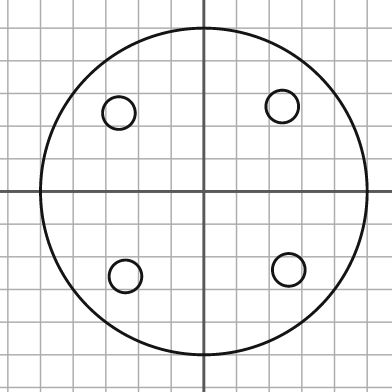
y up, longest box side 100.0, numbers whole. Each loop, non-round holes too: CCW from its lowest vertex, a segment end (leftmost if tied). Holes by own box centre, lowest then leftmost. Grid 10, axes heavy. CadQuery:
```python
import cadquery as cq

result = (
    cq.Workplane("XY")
    .moveTo(0.0, 0.0)
    .circle(50.0)
    .moveTo(-24.0, -26.0)
    .circle(5.0)
    .moveTo(26.0, -24.0)
    .circle(5.0)
    .moveTo(-26.0, 24.0)
    .circle(5.0)
    .moveTo(24.0, 26.0)
    .circle(5.0)
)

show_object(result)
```